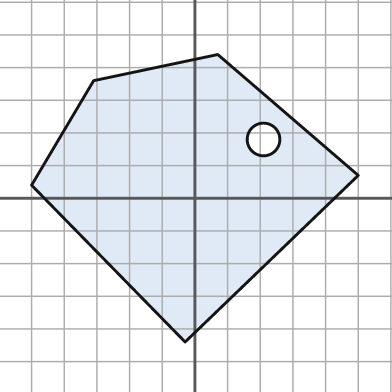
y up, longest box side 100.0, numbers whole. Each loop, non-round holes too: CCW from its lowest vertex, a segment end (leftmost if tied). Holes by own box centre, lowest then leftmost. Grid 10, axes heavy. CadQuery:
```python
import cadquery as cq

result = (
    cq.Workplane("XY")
    .moveTo(-3.0, -44.0)
    .lineTo(50.0, 7.0)
    .lineTo(7.0, 44.0)
    .lineTo(-31.0, 36.0)
    .lineTo(-50.0, 4.0)
    .close()
    .moveTo(21.0, 18.0)
    .circle(5.0)
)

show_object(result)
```